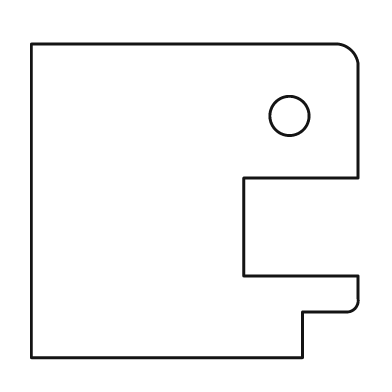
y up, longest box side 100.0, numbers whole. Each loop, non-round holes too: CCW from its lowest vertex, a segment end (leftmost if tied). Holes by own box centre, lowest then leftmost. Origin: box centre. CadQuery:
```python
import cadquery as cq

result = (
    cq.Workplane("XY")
    .moveTo(-50.0, -48.0)
    .lineTo(33.0, -48.0)
    .lineTo(33.0, -34.0)
    .lineTo(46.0, -34.0)
    .threePointArc((49.0, -33.0), (50.0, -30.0))
    .lineTo(50.0, -23.0)
    .lineTo(15.0, -23.0)
    .lineTo(15.0, 7.0)
    .lineTo(50.0, 7.0)
    .lineTo(50.0, 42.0)
    .threePointArc((48.0, 46.0), (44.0, 48.0))
    .lineTo(-50.0, 48.0)
    .close()
    .moveTo(29.0, 26.0)
    .circle(6.0)
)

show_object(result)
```